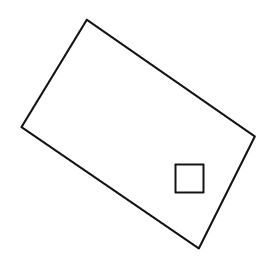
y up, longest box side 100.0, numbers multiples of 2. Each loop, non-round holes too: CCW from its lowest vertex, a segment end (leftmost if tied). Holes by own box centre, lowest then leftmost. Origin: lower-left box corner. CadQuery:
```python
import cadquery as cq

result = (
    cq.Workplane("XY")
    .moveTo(76.0, 0.0)
    .lineTo(100.0, 48.0)
    .lineTo(28.0, 98.0)
    .lineTo(0.0, 52.0)
    .close()
    .moveTo(66.0, 24.0)
    .lineTo(78.0, 24.0)
    .lineTo(78.0, 36.0)
    .lineTo(66.0, 36.0)
    .close()
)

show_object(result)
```